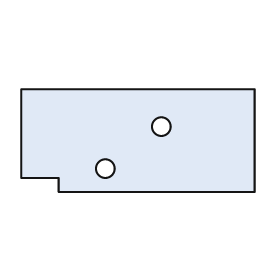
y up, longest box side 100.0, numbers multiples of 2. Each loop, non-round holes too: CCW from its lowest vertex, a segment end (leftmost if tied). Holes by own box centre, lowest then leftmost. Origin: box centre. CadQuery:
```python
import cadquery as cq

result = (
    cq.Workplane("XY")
    .moveTo(-34.0, -22.0)
    .lineTo(50.0, -22.0)
    .lineTo(50.0, 22.0)
    .lineTo(-50.0, 22.0)
    .lineTo(-50.0, -16.0)
    .lineTo(-34.0, -16.0)
    .close()
    .moveTo(-14.0, -12.0)
    .circle(4.0)
    .moveTo(10.0, 6.0)
    .circle(4.0)
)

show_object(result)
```